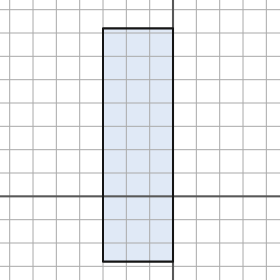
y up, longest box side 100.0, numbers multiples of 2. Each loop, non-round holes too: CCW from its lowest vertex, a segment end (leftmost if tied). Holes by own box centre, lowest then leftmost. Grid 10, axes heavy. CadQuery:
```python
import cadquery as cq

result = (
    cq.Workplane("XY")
    .moveTo(-30.0, -28.0)
    .lineTo(0.0, -28.0)
    .lineTo(0.0, 72.0)
    .lineTo(-30.0, 72.0)
    .close()
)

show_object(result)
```